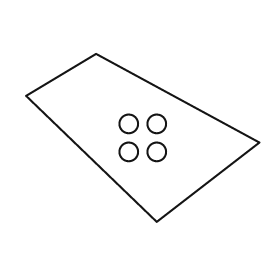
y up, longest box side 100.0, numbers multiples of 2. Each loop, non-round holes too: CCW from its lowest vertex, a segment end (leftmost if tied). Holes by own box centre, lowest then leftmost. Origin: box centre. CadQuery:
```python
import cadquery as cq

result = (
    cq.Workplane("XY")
    .moveTo(6.0, -36.0)
    .lineTo(50.0, -2.0)
    .lineTo(-20.0, 36.0)
    .lineTo(-50.0, 18.0)
    .close()
    .moveTo(-6.0, -6.0)
    .circle(4.0)
    .moveTo(6.0, -6.0)
    .circle(4.0)
    .moveTo(-6.0, 6.0)
    .circle(4.0)
    .moveTo(6.0, 6.0)
    .circle(4.0)
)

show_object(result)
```